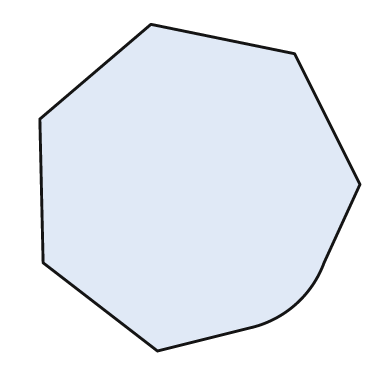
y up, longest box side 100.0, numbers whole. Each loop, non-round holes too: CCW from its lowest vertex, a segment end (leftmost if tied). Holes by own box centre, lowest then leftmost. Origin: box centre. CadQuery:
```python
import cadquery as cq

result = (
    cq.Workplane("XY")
    .moveTo(-13.0, -50.0)
    .lineTo(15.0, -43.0)
    .threePointArc((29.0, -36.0), (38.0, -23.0))
    .lineTo(49.0, 1.0)
    .lineTo(29.0, 41.0)
    .lineTo(-15.0, 50.0)
    .lineTo(-49.0, 21.0)
    .lineTo(-48.0, -23.0)
    .close()
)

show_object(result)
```